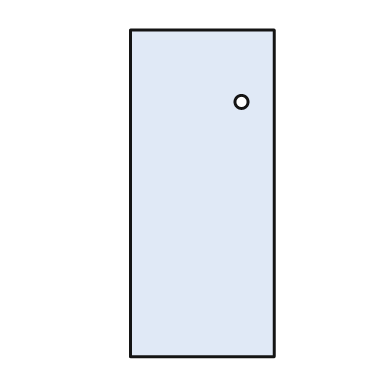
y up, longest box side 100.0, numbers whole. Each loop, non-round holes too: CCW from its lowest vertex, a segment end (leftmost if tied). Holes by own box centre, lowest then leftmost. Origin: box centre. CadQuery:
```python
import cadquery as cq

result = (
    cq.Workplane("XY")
    .moveTo(-22.0, -50.0)
    .lineTo(22.0, -50.0)
    .lineTo(22.0, 50.0)
    .lineTo(-22.0, 50.0)
    .close()
    .moveTo(12.0, 28.0)
    .circle(2.0)
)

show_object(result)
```